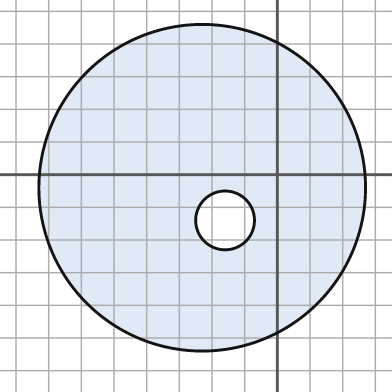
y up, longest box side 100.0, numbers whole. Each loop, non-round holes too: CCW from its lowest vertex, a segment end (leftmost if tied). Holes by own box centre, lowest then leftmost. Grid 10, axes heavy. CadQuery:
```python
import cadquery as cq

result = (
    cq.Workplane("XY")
    .moveTo(-23.0, -4.0)
    .circle(50.0)
    .moveTo(-16.0, -14.0)
    .circle(9.0)
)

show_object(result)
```